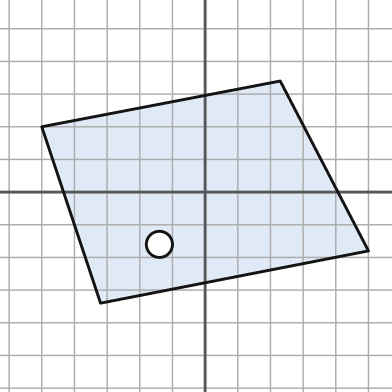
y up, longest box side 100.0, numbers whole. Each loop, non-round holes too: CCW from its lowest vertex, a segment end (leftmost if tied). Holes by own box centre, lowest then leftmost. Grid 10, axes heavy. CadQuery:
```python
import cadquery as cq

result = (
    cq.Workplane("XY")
    .moveTo(-32.0, -34.0)
    .lineTo(50.0, -18.0)
    .lineTo(23.0, 34.0)
    .lineTo(-50.0, 20.0)
    .close()
    .moveTo(-14.0, -16.0)
    .circle(4.0)
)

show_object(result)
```